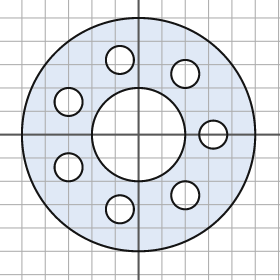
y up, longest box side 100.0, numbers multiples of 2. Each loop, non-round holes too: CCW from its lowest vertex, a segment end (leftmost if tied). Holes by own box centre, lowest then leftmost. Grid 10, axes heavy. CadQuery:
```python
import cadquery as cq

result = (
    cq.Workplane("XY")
    .moveTo(0.0, 0.0)
    .circle(50.0)
    .moveTo(-8.0, -32.0)
    .circle(6.0)
    .moveTo(20.0, -26.0)
    .circle(6.0)
    .moveTo(-30.0, -14.0)
    .circle(6.0)
    .moveTo(0.0, 0.0)
    .circle(20.0)
    .moveTo(32.0, 0.0)
    .circle(6.0)
    .moveTo(-30.0, 14.0)
    .circle(6.0)
    .moveTo(20.0, 26.0)
    .circle(6.0)
    .moveTo(-8.0, 32.0)
    .circle(6.0)
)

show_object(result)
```